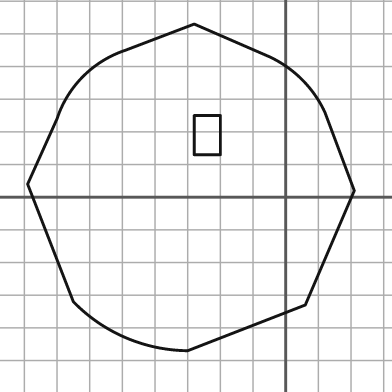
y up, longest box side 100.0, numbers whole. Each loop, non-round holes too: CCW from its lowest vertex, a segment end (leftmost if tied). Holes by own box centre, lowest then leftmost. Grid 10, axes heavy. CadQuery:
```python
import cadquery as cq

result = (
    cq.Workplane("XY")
    .moveTo(-30.0, -47.0)
    .lineTo(6.0, -33.0)
    .lineTo(21.0, 2.0)
    .lineTo(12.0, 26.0)
    .threePointArc((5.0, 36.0), (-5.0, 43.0))
    .lineTo(-28.0, 53.0)
    .lineTo(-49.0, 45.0)
    .threePointArc((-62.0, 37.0), (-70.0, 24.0))
    .lineTo(-79.0, 4.0)
    .lineTo(-65.0, -32.0)
    .threePointArc((-49.0, -43.0), (-30.0, -47.0))
    .close()
    .moveTo(-28.0, 13.0)
    .lineTo(-20.0, 13.0)
    .lineTo(-20.0, 25.0)
    .lineTo(-28.0, 25.0)
    .close()
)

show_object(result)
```